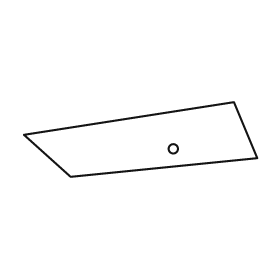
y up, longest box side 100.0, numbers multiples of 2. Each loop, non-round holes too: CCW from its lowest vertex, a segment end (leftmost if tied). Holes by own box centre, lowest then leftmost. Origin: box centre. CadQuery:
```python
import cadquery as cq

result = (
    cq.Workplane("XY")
    .moveTo(-30.0, -16.0)
    .lineTo(50.0, -8.0)
    .lineTo(40.0, 16.0)
    .lineTo(-50.0, 2.0)
    .close()
    .moveTo(14.0, -4.0)
    .circle(2.0)
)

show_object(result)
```